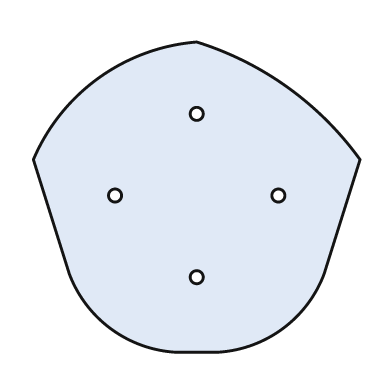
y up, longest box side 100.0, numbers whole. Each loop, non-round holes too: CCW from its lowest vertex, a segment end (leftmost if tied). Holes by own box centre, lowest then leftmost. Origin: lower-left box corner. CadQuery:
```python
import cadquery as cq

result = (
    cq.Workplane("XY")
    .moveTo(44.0, 0.0)
    .lineTo(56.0, 0.0)
    .threePointArc((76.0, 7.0), (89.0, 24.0))
    .lineTo(100.0, 59.0)
    .threePointArc((78.0, 81.0), (50.0, 95.0))
    .threePointArc((20.0, 84.0), (0.0, 59.0))
    .lineTo(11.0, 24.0)
    .threePointArc((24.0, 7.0), (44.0, 0.0))
    .close()
    .moveTo(50.0, 23.0)
    .circle(2.0)
    .moveTo(25.0, 48.0)
    .circle(2.0)
    .moveTo(75.0, 48.0)
    .circle(2.0)
    .moveTo(50.0, 73.0)
    .circle(2.0)
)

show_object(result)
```